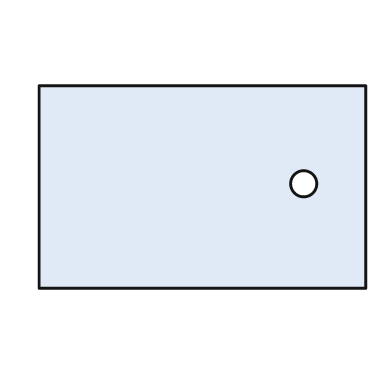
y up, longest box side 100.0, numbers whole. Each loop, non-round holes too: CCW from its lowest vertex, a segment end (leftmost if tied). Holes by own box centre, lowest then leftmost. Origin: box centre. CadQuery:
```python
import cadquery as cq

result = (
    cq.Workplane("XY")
    .moveTo(-50.0, -31.0)
    .lineTo(50.0, -31.0)
    .lineTo(50.0, 31.0)
    .lineTo(-50.0, 31.0)
    .close()
    .moveTo(31.0, 1.0)
    .circle(4.0)
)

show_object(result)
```